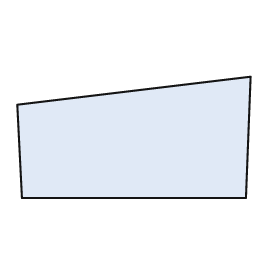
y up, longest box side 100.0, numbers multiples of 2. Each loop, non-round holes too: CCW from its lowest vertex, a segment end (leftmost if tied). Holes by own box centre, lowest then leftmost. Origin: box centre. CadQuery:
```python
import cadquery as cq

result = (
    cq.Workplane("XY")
    .moveTo(-48.0, -26.0)
    .lineTo(48.0, -26.0)
    .lineTo(50.0, 26.0)
    .lineTo(-50.0, 14.0)
    .close()
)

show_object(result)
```